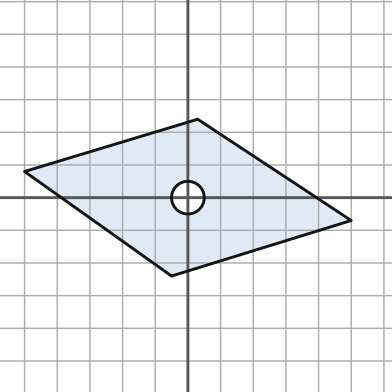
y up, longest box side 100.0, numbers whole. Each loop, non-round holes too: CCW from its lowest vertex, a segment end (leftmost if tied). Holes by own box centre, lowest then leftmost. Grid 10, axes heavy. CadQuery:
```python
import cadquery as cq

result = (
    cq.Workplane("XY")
    .moveTo(-5.0, -24.0)
    .lineTo(50.0, -7.0)
    .lineTo(3.0, 24.0)
    .lineTo(-50.0, 8.0)
    .close()
    .moveTo(0.0, 0.0)
    .circle(5.0)
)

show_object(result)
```